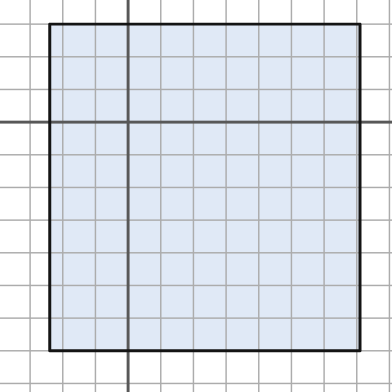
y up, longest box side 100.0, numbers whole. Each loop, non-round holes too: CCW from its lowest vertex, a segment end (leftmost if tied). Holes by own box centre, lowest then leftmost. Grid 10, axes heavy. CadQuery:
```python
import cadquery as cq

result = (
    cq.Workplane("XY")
    .moveTo(-24.0, -70.0)
    .lineTo(71.0, -70.0)
    .lineTo(71.0, 30.0)
    .lineTo(-24.0, 30.0)
    .close()
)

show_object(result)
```